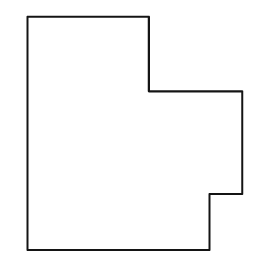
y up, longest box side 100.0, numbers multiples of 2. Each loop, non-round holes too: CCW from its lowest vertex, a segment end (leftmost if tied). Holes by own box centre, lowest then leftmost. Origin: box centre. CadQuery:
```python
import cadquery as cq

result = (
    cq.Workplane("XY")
    .moveTo(-46.0, -50.0)
    .lineTo(32.0, -50.0)
    .lineTo(32.0, -26.0)
    .lineTo(46.0, -26.0)
    .lineTo(46.0, 18.0)
    .lineTo(6.0, 18.0)
    .lineTo(6.0, 50.0)
    .lineTo(-46.0, 50.0)
    .close()
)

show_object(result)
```